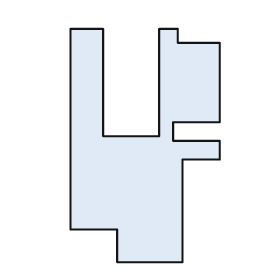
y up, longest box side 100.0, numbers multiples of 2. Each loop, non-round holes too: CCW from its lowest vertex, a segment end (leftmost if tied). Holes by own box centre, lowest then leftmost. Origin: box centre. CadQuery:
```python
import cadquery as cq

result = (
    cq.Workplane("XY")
    .moveTo(-12.0, -50.0)
    .lineTo(16.0, -50.0)
    .lineTo(16.0, -6.0)
    .lineTo(32.0, -6.0)
    .lineTo(32.0, 2.0)
    .lineTo(12.0, 2.0)
    .lineTo(12.0, 10.0)
    .lineTo(32.0, 10.0)
    .lineTo(32.0, 44.0)
    .lineTo(14.0, 44.0)
    .lineTo(14.0, 50.0)
    .lineTo(6.0, 50.0)
    .lineTo(6.0, 4.0)
    .lineTo(-18.0, 4.0)
    .lineTo(-18.0, 50.0)
    .lineTo(-32.0, 50.0)
    .lineTo(-32.0, -36.0)
    .lineTo(-12.0, -36.0)
    .close()
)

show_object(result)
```